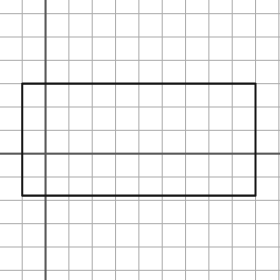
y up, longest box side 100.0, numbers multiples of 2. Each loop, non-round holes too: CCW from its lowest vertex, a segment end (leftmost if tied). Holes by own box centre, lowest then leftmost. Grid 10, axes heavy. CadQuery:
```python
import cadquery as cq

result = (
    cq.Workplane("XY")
    .moveTo(-10.0, -18.0)
    .lineTo(90.0, -18.0)
    .lineTo(90.0, 30.0)
    .lineTo(-10.0, 30.0)
    .close()
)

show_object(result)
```